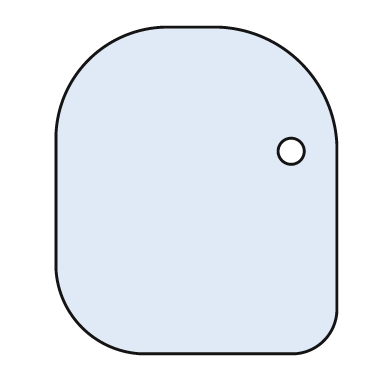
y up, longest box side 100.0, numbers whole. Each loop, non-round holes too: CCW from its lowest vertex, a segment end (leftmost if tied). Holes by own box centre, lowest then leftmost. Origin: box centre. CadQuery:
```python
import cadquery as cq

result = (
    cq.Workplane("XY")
    .moveTo(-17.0, -50.0)
    .lineTo(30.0, -50.0)
    .threePointArc((39.0, -46.0), (43.0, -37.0))
    .lineTo(43.0, 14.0)
    .threePointArc((32.0, 39.0), (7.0, 50.0))
    .lineTo(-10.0, 50.0)
    .threePointArc((-33.0, 40.0), (-43.0, 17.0))
    .lineTo(-43.0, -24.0)
    .threePointArc((-35.0, -42.0), (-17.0, -50.0))
    .close()
    .moveTo(29.0, 12.0)
    .circle(4.0)
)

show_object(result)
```